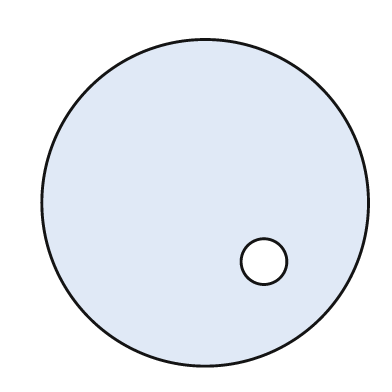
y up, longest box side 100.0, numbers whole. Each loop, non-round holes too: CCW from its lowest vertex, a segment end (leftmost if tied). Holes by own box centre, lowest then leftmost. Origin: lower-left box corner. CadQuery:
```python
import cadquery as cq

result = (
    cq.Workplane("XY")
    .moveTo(50.0, 50.0)
    .circle(50.0)
    .moveTo(68.0, 32.0)
    .circle(7.0)
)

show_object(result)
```